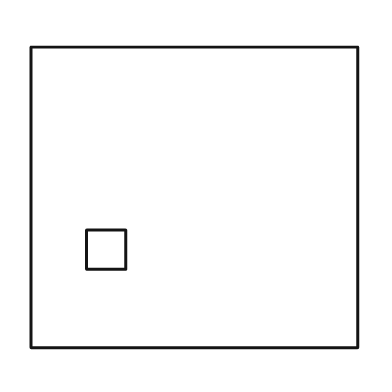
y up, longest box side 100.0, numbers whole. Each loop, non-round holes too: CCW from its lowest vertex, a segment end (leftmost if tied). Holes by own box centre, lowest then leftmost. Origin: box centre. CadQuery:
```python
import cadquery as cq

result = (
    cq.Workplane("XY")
    .moveTo(-50.0, -46.0)
    .lineTo(50.0, -46.0)
    .lineTo(50.0, 46.0)
    .lineTo(-50.0, 46.0)
    .close()
    .moveTo(-33.0, -22.0)
    .lineTo(-21.0, -22.0)
    .lineTo(-21.0, -10.0)
    .lineTo(-33.0, -10.0)
    .close()
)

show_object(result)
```